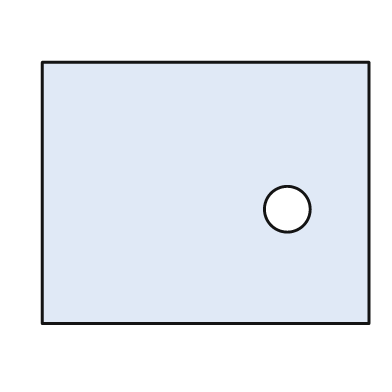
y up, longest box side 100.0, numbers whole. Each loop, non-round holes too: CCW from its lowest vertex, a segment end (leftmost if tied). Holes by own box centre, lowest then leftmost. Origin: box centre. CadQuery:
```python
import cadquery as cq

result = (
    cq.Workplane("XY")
    .moveTo(-50.0, -40.0)
    .lineTo(50.0, -40.0)
    .lineTo(50.0, 40.0)
    .lineTo(-50.0, 40.0)
    .close()
    .moveTo(25.0, -5.0)
    .circle(7.0)
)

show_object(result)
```